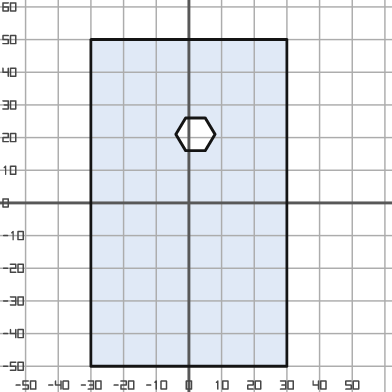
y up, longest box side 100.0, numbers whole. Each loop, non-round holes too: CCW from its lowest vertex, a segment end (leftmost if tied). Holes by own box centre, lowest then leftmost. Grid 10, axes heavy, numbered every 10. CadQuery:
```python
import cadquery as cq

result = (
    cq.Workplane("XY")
    .moveTo(-30.0, -50.0)
    .lineTo(30.0, -50.0)
    .lineTo(30.0, 50.0)
    .lineTo(-30.0, 50.0)
    .close()
    .moveTo(-1.0, 16.0)
    .lineTo(5.0, 16.0)
    .lineTo(8.0, 21.0)
    .lineTo(5.0, 26.0)
    .lineTo(-1.0, 26.0)
    .lineTo(-4.0, 21.0)
    .close()
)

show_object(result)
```